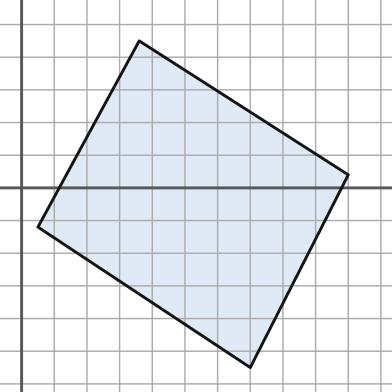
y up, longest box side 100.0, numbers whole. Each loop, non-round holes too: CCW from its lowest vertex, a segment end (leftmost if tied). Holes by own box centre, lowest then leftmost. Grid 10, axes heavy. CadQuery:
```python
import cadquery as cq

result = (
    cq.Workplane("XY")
    .moveTo(70.0, -55.0)
    .lineTo(100.0, 4.0)
    .lineTo(36.0, 45.0)
    .lineTo(5.0, -12.0)
    .close()
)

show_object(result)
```